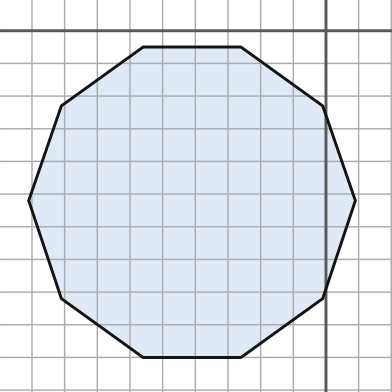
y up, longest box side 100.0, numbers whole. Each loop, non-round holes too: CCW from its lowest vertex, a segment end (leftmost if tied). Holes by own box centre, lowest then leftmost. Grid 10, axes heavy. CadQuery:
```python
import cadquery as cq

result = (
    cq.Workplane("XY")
    .moveTo(-56.0, -100.0)
    .lineTo(-26.0, -100.0)
    .lineTo(-1.0, -82.0)
    .lineTo(9.0, -52.0)
    .lineTo(-1.0, -23.0)
    .lineTo(-26.0, -5.0)
    .lineTo(-56.0, -5.0)
    .lineTo(-81.0, -23.0)
    .lineTo(-91.0, -52.0)
    .lineTo(-81.0, -82.0)
    .close()
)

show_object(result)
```